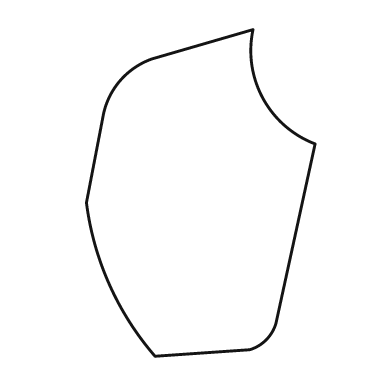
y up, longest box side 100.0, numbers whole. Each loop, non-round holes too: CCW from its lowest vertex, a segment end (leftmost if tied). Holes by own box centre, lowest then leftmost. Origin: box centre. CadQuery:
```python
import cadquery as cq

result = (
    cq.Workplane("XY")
    .moveTo(-14.0, -50.0)
    .lineTo(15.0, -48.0)
    .threePointArc((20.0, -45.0), (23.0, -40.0))
    .lineTo(35.0, 15.0)
    .threePointArc((19.0, 29.0), (16.0, 50.0))
    .lineTo(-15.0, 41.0)
    .threePointArc((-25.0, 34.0), (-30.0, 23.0))
    .lineTo(-35.0, -3.0)
    .threePointArc((-28.0, -28.0), (-14.0, -50.0))
    .close()
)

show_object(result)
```